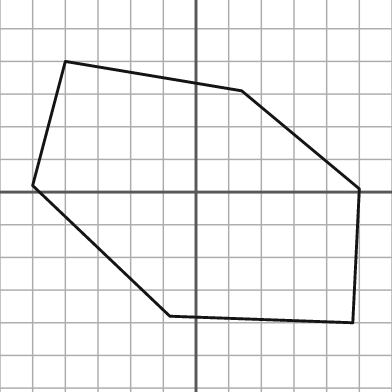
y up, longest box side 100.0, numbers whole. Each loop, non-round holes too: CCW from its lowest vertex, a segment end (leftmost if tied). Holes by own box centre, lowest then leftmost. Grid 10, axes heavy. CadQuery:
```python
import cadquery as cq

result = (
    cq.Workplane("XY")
    .moveTo(48.0, -40.0)
    .lineTo(50.0, 1.0)
    .lineTo(14.0, 31.0)
    .lineTo(-40.0, 40.0)
    .lineTo(-50.0, 2.0)
    .lineTo(-8.0, -38.0)
    .close()
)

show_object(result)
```